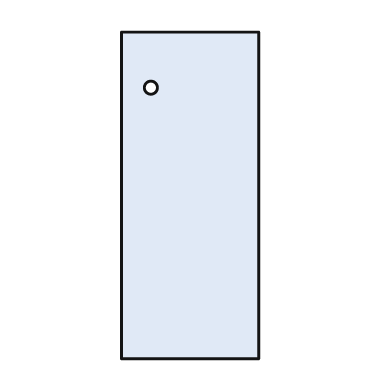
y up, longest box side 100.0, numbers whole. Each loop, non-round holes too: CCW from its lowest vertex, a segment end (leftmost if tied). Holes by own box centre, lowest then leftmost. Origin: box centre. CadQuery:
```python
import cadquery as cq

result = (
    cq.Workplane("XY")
    .moveTo(-21.0, -50.0)
    .lineTo(21.0, -50.0)
    .lineTo(21.0, 50.0)
    .lineTo(-21.0, 50.0)
    .close()
    .moveTo(-12.0, 33.0)
    .circle(2.0)
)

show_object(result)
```